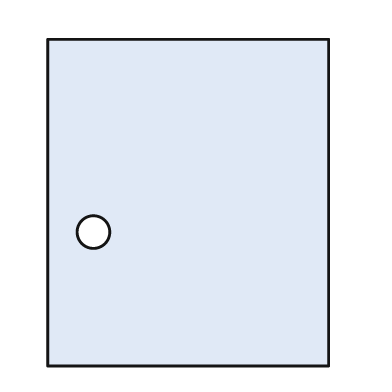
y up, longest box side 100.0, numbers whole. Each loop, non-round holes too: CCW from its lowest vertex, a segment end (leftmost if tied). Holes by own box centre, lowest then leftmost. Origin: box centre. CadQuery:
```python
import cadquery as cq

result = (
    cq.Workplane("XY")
    .moveTo(-43.0, -50.0)
    .lineTo(43.0, -50.0)
    .lineTo(43.0, 50.0)
    .lineTo(-43.0, 50.0)
    .close()
    .moveTo(-29.0, -9.0)
    .circle(5.0)
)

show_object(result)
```